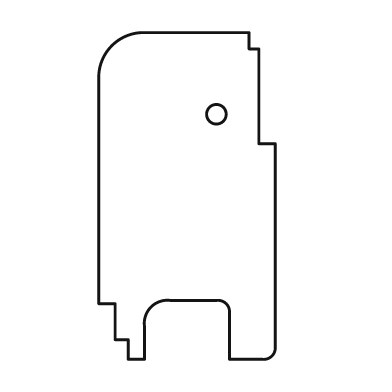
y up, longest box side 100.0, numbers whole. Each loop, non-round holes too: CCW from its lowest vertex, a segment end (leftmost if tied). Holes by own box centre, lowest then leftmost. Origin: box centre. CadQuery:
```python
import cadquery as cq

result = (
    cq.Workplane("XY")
    .moveTo(-18.0, -50.0)
    .lineTo(-13.0, -50.0)
    .lineTo(-13.0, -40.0)
    .threePointArc((-11.0, -34.0), (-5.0, -32.0))
    .lineTo(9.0, -32.0)
    .threePointArc((12.0, -33.0), (13.0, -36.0))
    .lineTo(13.0, -50.0)
    .lineTo(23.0, -50.0)
    .threePointArc((26.0, -49.0), (27.0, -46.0))
    .lineTo(27.0, 16.0)
    .lineTo(22.0, 16.0)
    .lineTo(22.0, 45.0)
    .lineTo(19.0, 45.0)
    .lineTo(19.0, 50.0)
    .lineTo(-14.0, 50.0)
    .threePointArc((-23.0, 46.0), (-27.0, 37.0))
    .lineTo(-27.0, -33.0)
    .lineTo(-22.0, -33.0)
    .lineTo(-22.0, -44.0)
    .lineTo(-18.0, -44.0)
    .close()
    .moveTo(9.0, 25.0)
    .circle(3.0)
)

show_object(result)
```